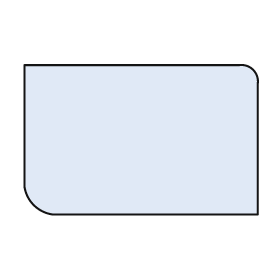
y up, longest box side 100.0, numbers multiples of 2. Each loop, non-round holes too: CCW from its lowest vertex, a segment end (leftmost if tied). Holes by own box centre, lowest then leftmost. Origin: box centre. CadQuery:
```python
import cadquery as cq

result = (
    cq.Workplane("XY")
    .moveTo(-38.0, -32.0)
    .lineTo(50.0, -32.0)
    .lineTo(50.0, 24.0)
    .threePointArc((48.0, 30.0), (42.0, 32.0))
    .lineTo(-50.0, 32.0)
    .lineTo(-50.0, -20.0)
    .threePointArc((-46.0, -28.0), (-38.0, -32.0))
    .close()
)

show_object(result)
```